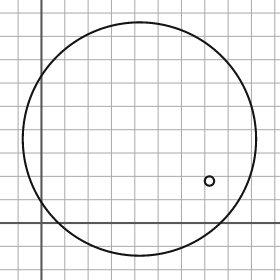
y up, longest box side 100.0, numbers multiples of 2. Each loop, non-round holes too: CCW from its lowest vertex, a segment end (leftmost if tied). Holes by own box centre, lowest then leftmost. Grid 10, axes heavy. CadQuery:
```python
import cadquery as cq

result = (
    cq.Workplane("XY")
    .moveTo(42.0, 36.0)
    .circle(50.0)
    .moveTo(72.0, 18.0)
    .circle(2.0)
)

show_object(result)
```